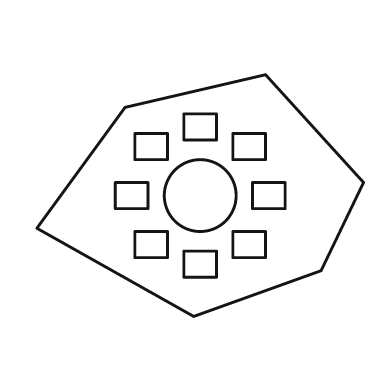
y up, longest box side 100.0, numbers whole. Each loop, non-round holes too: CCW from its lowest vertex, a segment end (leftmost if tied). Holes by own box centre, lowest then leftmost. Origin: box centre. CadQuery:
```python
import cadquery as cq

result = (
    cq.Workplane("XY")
    .moveTo(-2.0, -37.0)
    .lineTo(37.0, -23.0)
    .lineTo(50.0, 4.0)
    .lineTo(20.0, 37.0)
    .lineTo(-23.0, 27.0)
    .lineTo(-50.0, -10.0)
    .close()
    .moveTo(-5.0, -25.0)
    .lineTo(5.0, -25.0)
    .lineTo(5.0, -17.0)
    .lineTo(-5.0, -17.0)
    .close()
    .moveTo(-20.0, -19.0)
    .lineTo(-10.0, -19.0)
    .lineTo(-10.0, -11.0)
    .lineTo(-20.0, -11.0)
    .close()
    .moveTo(10.0, -19.0)
    .lineTo(20.0, -19.0)
    .lineTo(20.0, -11.0)
    .lineTo(10.0, -11.0)
    .close()
    .moveTo(-26.0, -4.0)
    .lineTo(-16.0, -4.0)
    .lineTo(-16.0, 4.0)
    .lineTo(-26.0, 4.0)
    .close()
    .moveTo(0.0, 0.0)
    .circle(11.0)
    .moveTo(16.0, -4.0)
    .lineTo(26.0, -4.0)
    .lineTo(26.0, 4.0)
    .lineTo(16.0, 4.0)
    .close()
    .moveTo(-20.0, 11.0)
    .lineTo(-10.0, 11.0)
    .lineTo(-10.0, 19.0)
    .lineTo(-20.0, 19.0)
    .close()
    .moveTo(10.0, 11.0)
    .lineTo(20.0, 11.0)
    .lineTo(20.0, 19.0)
    .lineTo(10.0, 19.0)
    .close()
    .moveTo(-5.0, 17.0)
    .lineTo(5.0, 17.0)
    .lineTo(5.0, 25.0)
    .lineTo(-5.0, 25.0)
    .close()
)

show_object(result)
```